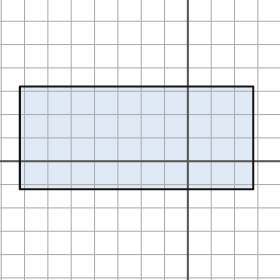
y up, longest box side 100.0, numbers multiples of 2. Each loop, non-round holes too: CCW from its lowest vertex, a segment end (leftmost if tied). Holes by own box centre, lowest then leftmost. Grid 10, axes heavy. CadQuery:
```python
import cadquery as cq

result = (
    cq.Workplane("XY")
    .moveTo(-72.0, -12.0)
    .lineTo(28.0, -12.0)
    .lineTo(28.0, 32.0)
    .lineTo(-72.0, 32.0)
    .close()
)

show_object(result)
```